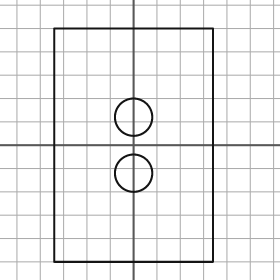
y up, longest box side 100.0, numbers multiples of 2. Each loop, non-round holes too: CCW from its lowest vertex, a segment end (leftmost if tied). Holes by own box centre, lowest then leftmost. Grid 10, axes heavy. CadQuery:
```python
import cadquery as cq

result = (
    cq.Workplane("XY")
    .moveTo(-34.0, -50.0)
    .lineTo(34.0, -50.0)
    .lineTo(34.0, 50.0)
    .lineTo(-34.0, 50.0)
    .close()
    .moveTo(0.0, -12.0)
    .circle(8.0)
    .moveTo(0.0, 12.0)
    .circle(8.0)
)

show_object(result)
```